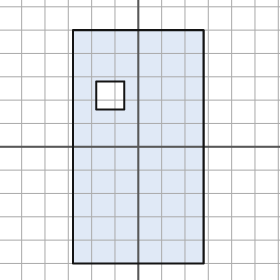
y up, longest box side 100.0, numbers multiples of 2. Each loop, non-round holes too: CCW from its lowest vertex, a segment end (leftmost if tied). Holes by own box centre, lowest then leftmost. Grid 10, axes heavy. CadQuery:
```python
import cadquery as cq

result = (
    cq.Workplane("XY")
    .moveTo(-28.0, -50.0)
    .lineTo(28.0, -50.0)
    .lineTo(28.0, 50.0)
    .lineTo(-28.0, 50.0)
    .close()
    .moveTo(-18.0, 16.0)
    .lineTo(-6.0, 16.0)
    .lineTo(-6.0, 28.0)
    .lineTo(-18.0, 28.0)
    .close()
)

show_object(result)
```